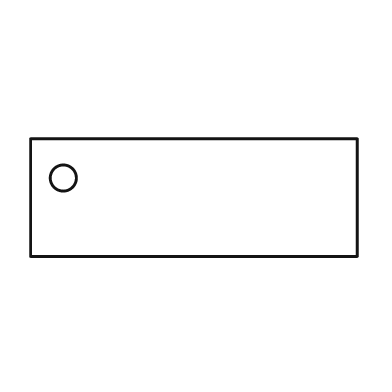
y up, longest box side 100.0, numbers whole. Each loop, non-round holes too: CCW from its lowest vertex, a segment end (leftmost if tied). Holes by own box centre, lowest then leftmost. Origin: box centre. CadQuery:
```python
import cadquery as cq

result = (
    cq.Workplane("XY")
    .moveTo(-50.0, -18.0)
    .lineTo(50.0, -18.0)
    .lineTo(50.0, 18.0)
    .lineTo(-50.0, 18.0)
    .close()
    .moveTo(-40.0, 6.0)
    .circle(4.0)
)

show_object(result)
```